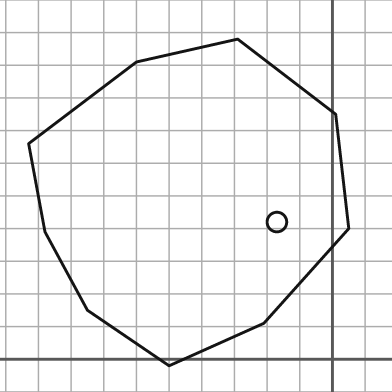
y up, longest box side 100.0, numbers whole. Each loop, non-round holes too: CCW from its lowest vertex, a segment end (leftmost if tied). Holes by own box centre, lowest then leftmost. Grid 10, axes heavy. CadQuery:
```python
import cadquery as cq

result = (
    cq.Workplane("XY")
    .moveTo(-50.0, -2.0)
    .lineTo(-21.0, 11.0)
    .lineTo(5.0, 40.0)
    .lineTo(1.0, 75.0)
    .lineTo(-29.0, 98.0)
    .lineTo(-60.0, 91.0)
    .lineTo(-93.0, 66.0)
    .lineTo(-88.0, 39.0)
    .lineTo(-75.0, 15.0)
    .close()
    .moveTo(-17.0, 42.0)
    .circle(3.0)
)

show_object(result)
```